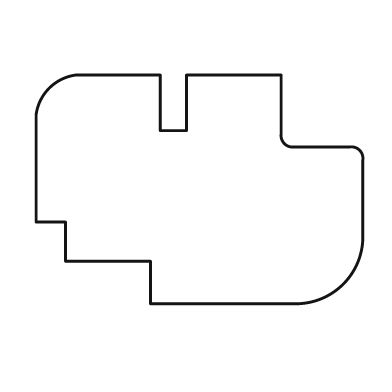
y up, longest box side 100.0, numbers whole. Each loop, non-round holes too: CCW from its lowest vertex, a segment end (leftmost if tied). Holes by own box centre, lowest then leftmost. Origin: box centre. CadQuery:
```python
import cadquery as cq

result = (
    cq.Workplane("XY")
    .moveTo(-15.0, -35.0)
    .lineTo(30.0, -35.0)
    .threePointArc((44.0, -29.0), (50.0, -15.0))
    .lineTo(50.0, 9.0)
    .threePointArc((49.0, 12.0), (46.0, 13.0))
    .lineTo(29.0, 13.0)
    .threePointArc((26.0, 14.0), (25.0, 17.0))
    .lineTo(25.0, 35.0)
    .lineTo(-4.0, 35.0)
    .lineTo(-4.0, 18.0)
    .lineTo(-12.0, 18.0)
    .lineTo(-12.0, 35.0)
    .lineTo(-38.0, 35.0)
    .threePointArc((-46.0, 31.0), (-50.0, 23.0))
    .lineTo(-50.0, -10.0)
    .lineTo(-41.0, -10.0)
    .lineTo(-41.0, -22.0)
    .lineTo(-15.0, -22.0)
    .close()
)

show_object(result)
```